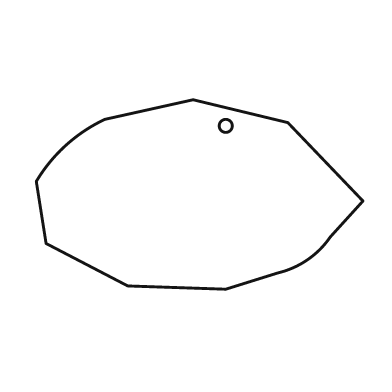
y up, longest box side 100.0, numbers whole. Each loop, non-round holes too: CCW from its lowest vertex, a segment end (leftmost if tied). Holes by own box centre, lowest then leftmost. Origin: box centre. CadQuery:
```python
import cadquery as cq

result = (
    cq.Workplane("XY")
    .moveTo(8.0, -29.0)
    .lineTo(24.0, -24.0)
    .threePointArc((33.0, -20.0), (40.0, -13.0))
    .lineTo(50.0, -2.0)
    .lineTo(27.0, 22.0)
    .lineTo(-2.0, 29.0)
    .lineTo(-29.0, 23.0)
    .threePointArc((-41.0, 15.0), (-50.0, 4.0))
    .lineTo(-47.0, -15.0)
    .lineTo(-22.0, -28.0)
    .close()
    .moveTo(8.0, 21.0)
    .circle(2.0)
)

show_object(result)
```